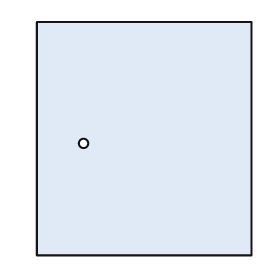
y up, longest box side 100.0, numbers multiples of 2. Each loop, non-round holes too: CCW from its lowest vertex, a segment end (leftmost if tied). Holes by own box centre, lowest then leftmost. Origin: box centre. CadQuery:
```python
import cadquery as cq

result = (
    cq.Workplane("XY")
    .moveTo(-46.0, -50.0)
    .lineTo(46.0, -50.0)
    .lineTo(46.0, 50.0)
    .lineTo(-46.0, 50.0)
    .close()
    .moveTo(-26.0, -2.0)
    .circle(2.0)
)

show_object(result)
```